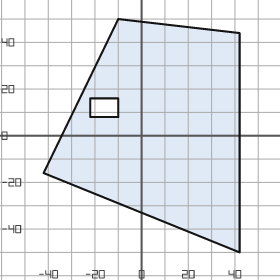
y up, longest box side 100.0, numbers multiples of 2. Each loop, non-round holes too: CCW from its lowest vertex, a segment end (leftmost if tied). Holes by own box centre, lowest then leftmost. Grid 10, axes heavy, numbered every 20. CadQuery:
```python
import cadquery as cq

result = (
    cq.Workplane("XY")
    .moveTo(42.0, -50.0)
    .lineTo(42.0, 44.0)
    .lineTo(-10.0, 50.0)
    .lineTo(-42.0, -16.0)
    .close()
    .moveTo(-22.0, 8.0)
    .lineTo(-10.0, 8.0)
    .lineTo(-10.0, 16.0)
    .lineTo(-22.0, 16.0)
    .close()
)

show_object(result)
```